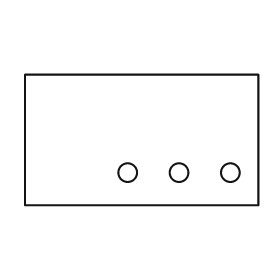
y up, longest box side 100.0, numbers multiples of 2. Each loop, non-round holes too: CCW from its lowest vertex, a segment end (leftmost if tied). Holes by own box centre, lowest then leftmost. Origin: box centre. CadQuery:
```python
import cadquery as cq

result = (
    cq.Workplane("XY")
    .moveTo(-50.0, -28.0)
    .lineTo(50.0, -28.0)
    .lineTo(50.0, 28.0)
    .lineTo(-50.0, 28.0)
    .close()
    .moveTo(-6.0, -14.0)
    .circle(4.0)
    .moveTo(16.0, -14.0)
    .circle(4.0)
    .moveTo(38.0, -14.0)
    .circle(4.0)
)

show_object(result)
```